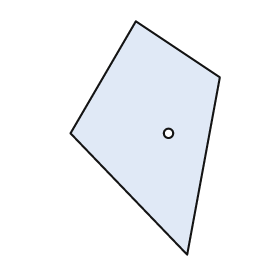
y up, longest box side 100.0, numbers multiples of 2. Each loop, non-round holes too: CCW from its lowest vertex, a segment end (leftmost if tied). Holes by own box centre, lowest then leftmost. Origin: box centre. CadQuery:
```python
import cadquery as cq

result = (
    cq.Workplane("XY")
    .moveTo(18.0, -50.0)
    .lineTo(32.0, 26.0)
    .lineTo(-4.0, 50.0)
    .lineTo(-32.0, 2.0)
    .close()
    .moveTo(10.0, 2.0)
    .circle(2.0)
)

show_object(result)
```